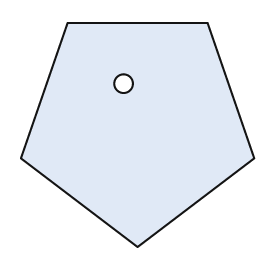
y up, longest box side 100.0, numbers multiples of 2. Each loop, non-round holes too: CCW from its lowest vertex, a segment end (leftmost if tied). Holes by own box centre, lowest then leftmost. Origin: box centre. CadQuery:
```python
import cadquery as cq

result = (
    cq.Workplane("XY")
    .moveTo(0.0, -48.0)
    .lineTo(50.0, -10.0)
    .lineTo(30.0, 48.0)
    .lineTo(-30.0, 48.0)
    .lineTo(-50.0, -10.0)
    .close()
    .moveTo(-6.0, 22.0)
    .circle(4.0)
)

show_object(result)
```